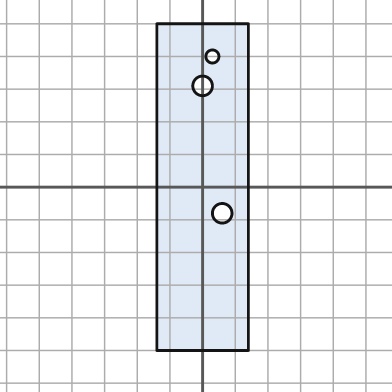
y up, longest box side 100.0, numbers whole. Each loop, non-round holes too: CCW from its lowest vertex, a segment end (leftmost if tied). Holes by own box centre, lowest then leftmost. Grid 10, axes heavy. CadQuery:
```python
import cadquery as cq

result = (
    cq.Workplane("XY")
    .moveTo(-14.0, -50.0)
    .lineTo(14.0, -50.0)
    .lineTo(14.0, 50.0)
    .lineTo(-14.0, 50.0)
    .close()
    .moveTo(6.0, -8.0)
    .circle(3.0)
    .moveTo(0.0, 31.0)
    .circle(3.0)
    .moveTo(3.0, 40.0)
    .circle(2.0)
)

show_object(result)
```